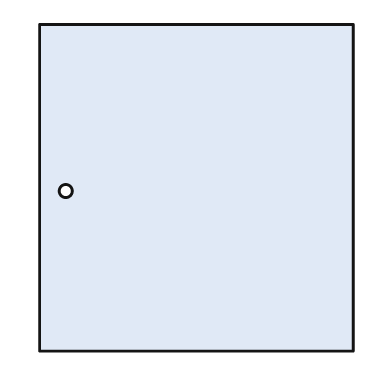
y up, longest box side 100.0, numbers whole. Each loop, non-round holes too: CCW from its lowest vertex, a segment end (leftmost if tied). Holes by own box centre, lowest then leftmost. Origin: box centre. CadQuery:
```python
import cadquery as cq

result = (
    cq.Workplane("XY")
    .moveTo(-48.0, -50.0)
    .lineTo(48.0, -50.0)
    .lineTo(48.0, 50.0)
    .lineTo(-48.0, 50.0)
    .close()
    .moveTo(-40.0, -1.0)
    .circle(2.0)
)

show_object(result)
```